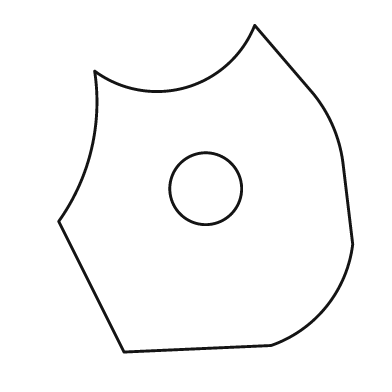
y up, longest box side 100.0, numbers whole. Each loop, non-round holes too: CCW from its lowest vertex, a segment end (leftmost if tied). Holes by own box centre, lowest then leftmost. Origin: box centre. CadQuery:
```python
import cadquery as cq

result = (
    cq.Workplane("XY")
    .moveTo(-25.0, -50.0)
    .lineTo(20.0, -48.0)
    .threePointArc((37.0, -36.0), (45.0, -17.0))
    .lineTo(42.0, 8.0)
    .threePointArc((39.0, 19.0), (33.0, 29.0))
    .lineTo(15.0, 50.0)
    .threePointArc((-6.0, 31.0), (-34.0, 36.0))
    .threePointArc((-35.0, 12.0), (-45.0, -10.0))
    .close()
    .moveTo(0.0, 0.0)
    .circle(11.0)
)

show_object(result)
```